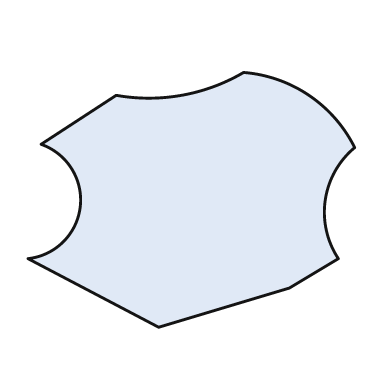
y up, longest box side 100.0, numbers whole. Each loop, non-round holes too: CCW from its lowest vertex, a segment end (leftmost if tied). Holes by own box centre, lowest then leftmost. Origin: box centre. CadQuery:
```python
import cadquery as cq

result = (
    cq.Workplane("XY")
    .moveTo(-10.0, -39.0)
    .lineTo(30.0, -27.0)
    .lineTo(45.0, -18.0)
    .threePointArc((41.0, 0.0), (50.0, 16.0))
    .threePointArc((36.0, 32.0), (16.0, 39.0))
    .threePointArc((-3.0, 32.0), (-23.0, 32.0))
    .lineTo(-46.0, 17.0)
    .threePointArc((-34.0, -2.0), (-50.0, -18.0))
    .close()
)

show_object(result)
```